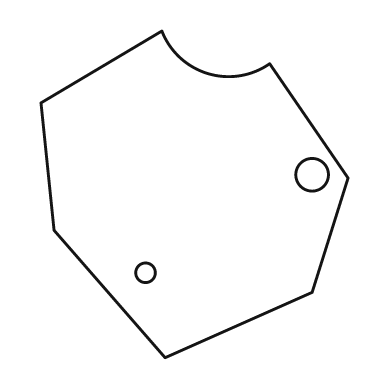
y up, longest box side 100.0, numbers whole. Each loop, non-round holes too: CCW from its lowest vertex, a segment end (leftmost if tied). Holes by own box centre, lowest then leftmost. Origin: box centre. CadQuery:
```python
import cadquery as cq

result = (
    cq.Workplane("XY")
    .moveTo(-9.0, -50.0)
    .lineTo(36.0, -30.0)
    .lineTo(47.0, 5.0)
    .lineTo(23.0, 40.0)
    .threePointArc((4.0, 37.0), (-10.0, 50.0))
    .lineTo(-47.0, 28.0)
    .lineTo(-43.0, -11.0)
    .close()
    .moveTo(-15.0, -24.0)
    .circle(3.0)
    .moveTo(36.0, 6.0)
    .circle(5.0)
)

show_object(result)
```